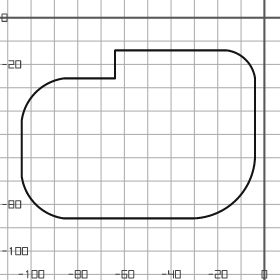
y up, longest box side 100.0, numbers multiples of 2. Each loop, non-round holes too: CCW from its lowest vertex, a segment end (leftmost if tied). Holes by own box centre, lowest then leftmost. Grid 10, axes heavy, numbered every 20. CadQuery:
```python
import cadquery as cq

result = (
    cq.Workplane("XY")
    .moveTo(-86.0, -86.0)
    .lineTo(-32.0, -86.0)
    .threePointArc((-12.0, -78.0), (-4.0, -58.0))
    .lineTo(-4.0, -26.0)
    .threePointArc((-8.0, -18.0), (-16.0, -14.0))
    .lineTo(-64.0, -14.0)
    .lineTo(-64.0, -26.0)
    .lineTo(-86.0, -26.0)
    .threePointArc((-98.0, -32.0), (-104.0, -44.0))
    .lineTo(-104.0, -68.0)
    .threePointArc((-98.0, -80.0), (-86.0, -86.0))
    .close()
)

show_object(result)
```